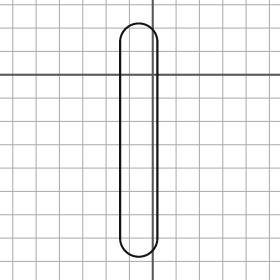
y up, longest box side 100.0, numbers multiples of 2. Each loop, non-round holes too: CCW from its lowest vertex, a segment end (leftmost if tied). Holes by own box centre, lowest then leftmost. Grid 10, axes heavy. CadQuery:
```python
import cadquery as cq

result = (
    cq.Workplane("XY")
    .moveTo(-14.0, -70.0)
    .threePointArc((-6.0, -78.0), (2.0, -70.0))
    .lineTo(2.0, 14.0)
    .threePointArc((-6.0, 22.0), (-14.0, 14.0))
    .close()
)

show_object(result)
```